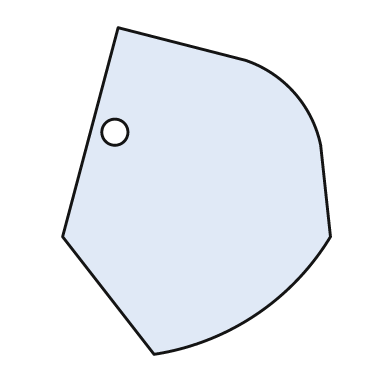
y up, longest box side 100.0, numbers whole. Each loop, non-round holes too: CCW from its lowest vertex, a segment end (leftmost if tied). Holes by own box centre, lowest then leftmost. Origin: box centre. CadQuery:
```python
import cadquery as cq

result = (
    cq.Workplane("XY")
    .moveTo(-13.0, -50.0)
    .threePointArc((18.0, -38.0), (41.0, -14.0))
    .lineTo(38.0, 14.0)
    .threePointArc((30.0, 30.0), (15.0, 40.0))
    .lineTo(-24.0, 50.0)
    .lineTo(-41.0, -14.0)
    .close()
    .moveTo(-25.0, 18.0)
    .circle(4.0)
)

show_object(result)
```